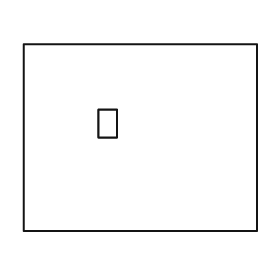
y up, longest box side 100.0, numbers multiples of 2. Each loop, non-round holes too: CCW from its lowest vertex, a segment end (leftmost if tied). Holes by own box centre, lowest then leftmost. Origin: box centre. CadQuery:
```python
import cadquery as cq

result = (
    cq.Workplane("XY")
    .moveTo(-50.0, -40.0)
    .lineTo(50.0, -40.0)
    .lineTo(50.0, 40.0)
    .lineTo(-50.0, 40.0)
    .close()
    .moveTo(-18.0, 0.0)
    .lineTo(-10.0, 0.0)
    .lineTo(-10.0, 12.0)
    .lineTo(-18.0, 12.0)
    .close()
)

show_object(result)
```